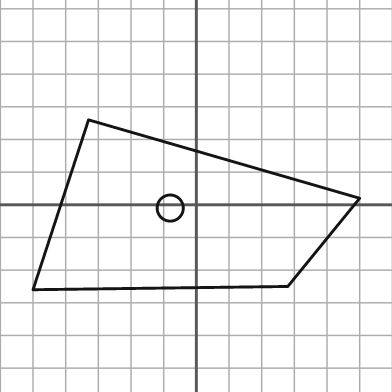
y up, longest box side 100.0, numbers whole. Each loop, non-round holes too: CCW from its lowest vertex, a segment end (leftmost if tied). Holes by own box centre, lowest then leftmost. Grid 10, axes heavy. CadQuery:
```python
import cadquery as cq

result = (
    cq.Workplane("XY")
    .moveTo(-50.0, -26.0)
    .lineTo(28.0, -25.0)
    .lineTo(50.0, 2.0)
    .lineTo(-33.0, 26.0)
    .close()
    .moveTo(-8.0, -1.0)
    .circle(4.0)
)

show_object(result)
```